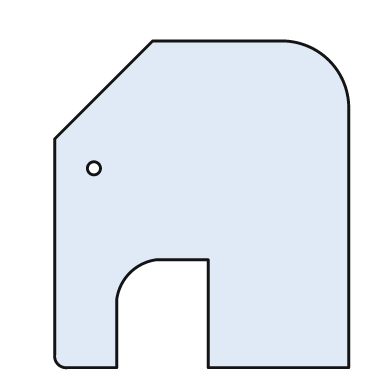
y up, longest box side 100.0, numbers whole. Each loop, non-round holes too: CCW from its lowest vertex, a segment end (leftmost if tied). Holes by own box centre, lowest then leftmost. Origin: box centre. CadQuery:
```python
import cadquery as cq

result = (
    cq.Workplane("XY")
    .moveTo(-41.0, -50.0)
    .lineTo(-26.0, -50.0)
    .lineTo(-26.0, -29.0)
    .threePointArc((-22.0, -21.0), (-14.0, -17.0))
    .lineTo(2.0, -17.0)
    .lineTo(2.0, -50.0)
    .lineTo(45.0, -50.0)
    .lineTo(45.0, 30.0)
    .threePointArc((39.0, 44.0), (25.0, 50.0))
    .lineTo(-15.0, 50.0)
    .lineTo(-45.0, 20.0)
    .lineTo(-45.0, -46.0)
    .threePointArc((-44.0, -49.0), (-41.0, -50.0))
    .close()
    .moveTo(-33.0, 11.0)
    .circle(2.0)
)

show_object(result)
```